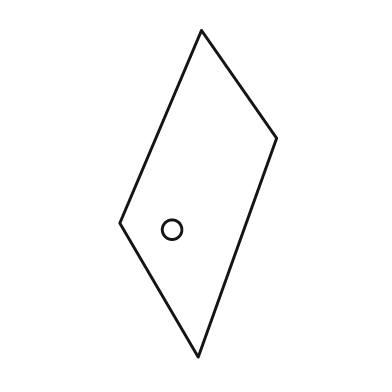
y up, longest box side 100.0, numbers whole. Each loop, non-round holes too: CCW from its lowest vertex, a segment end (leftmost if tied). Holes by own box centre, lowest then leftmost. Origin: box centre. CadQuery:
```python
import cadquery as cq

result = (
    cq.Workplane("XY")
    .moveTo(0.0, -50.0)
    .lineTo(24.0, 17.0)
    .lineTo(1.0, 50.0)
    .lineTo(-24.0, -9.0)
    .close()
    .moveTo(-8.0, -11.0)
    .circle(3.0)
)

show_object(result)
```